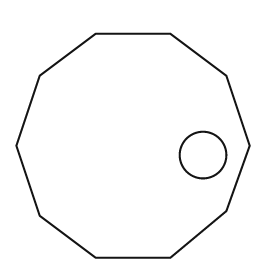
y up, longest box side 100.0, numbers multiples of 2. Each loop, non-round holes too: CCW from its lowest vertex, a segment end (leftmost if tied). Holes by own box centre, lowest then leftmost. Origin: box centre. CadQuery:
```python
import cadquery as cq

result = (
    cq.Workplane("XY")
    .moveTo(-16.0, -48.0)
    .lineTo(16.0, -48.0)
    .lineTo(40.0, -28.0)
    .lineTo(50.0, 0.0)
    .lineTo(40.0, 30.0)
    .lineTo(16.0, 48.0)
    .lineTo(-16.0, 48.0)
    .lineTo(-40.0, 30.0)
    .lineTo(-50.0, 0.0)
    .lineTo(-40.0, -30.0)
    .close()
    .moveTo(30.0, -4.0)
    .circle(10.0)
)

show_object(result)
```